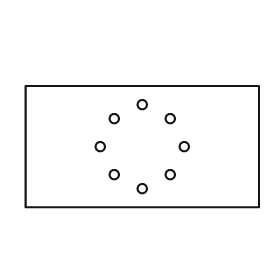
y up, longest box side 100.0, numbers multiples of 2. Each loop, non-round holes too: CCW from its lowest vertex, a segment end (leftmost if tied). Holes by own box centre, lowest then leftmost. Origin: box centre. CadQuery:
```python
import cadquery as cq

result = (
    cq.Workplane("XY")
    .moveTo(-50.0, -26.0)
    .lineTo(50.0, -26.0)
    .lineTo(50.0, 26.0)
    .lineTo(-50.0, 26.0)
    .close()
    .moveTo(0.0, -18.0)
    .circle(2.0)
    .moveTo(-12.0, -12.0)
    .circle(2.0)
    .moveTo(12.0, -12.0)
    .circle(2.0)
    .moveTo(-18.0, 0.0)
    .circle(2.0)
    .moveTo(18.0, 0.0)
    .circle(2.0)
    .moveTo(-12.0, 12.0)
    .circle(2.0)
    .moveTo(12.0, 12.0)
    .circle(2.0)
    .moveTo(0.0, 18.0)
    .circle(2.0)
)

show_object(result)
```